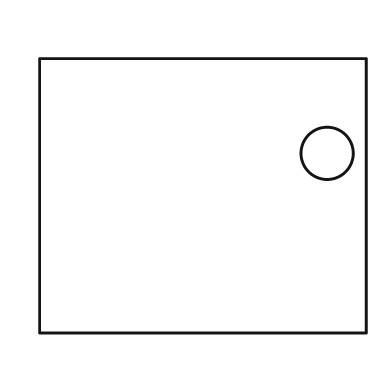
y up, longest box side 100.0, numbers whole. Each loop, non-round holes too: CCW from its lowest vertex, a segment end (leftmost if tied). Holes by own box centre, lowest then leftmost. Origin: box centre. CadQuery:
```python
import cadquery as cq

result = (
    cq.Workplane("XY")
    .moveTo(-50.0, -42.0)
    .lineTo(50.0, -42.0)
    .lineTo(50.0, 42.0)
    .lineTo(-50.0, 42.0)
    .close()
    .moveTo(38.0, 13.0)
    .circle(8.0)
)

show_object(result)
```